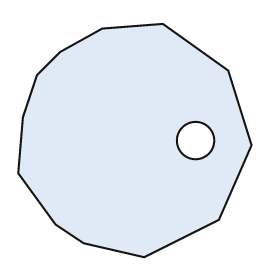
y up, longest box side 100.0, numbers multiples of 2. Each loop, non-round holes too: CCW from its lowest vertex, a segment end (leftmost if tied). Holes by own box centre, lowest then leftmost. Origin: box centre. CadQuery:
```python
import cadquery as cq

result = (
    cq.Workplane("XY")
    .moveTo(4.0, -50.0)
    .lineTo(36.0, -34.0)
    .lineTo(50.0, -2.0)
    .lineTo(40.0, 30.0)
    .lineTo(12.0, 50.0)
    .lineTo(-14.0, 48.0)
    .lineTo(-32.0, 38.0)
    .lineTo(-42.0, 28.0)
    .lineTo(-48.0, 10.0)
    .lineTo(-50.0, -14.0)
    .lineTo(-34.0, -36.0)
    .lineTo(-22.0, -44.0)
    .close()
    .moveTo(26.0, 0.0)
    .circle(8.0)
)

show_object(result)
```